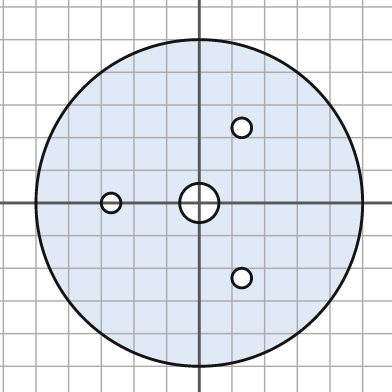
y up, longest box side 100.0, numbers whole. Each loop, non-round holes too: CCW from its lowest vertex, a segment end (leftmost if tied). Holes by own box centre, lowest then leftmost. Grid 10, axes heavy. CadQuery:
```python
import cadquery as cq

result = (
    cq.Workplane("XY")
    .moveTo(0.0, 0.0)
    .circle(50.0)
    .moveTo(13.0, -23.0)
    .circle(3.0)
    .moveTo(-27.0, 0.0)
    .circle(3.0)
    .moveTo(0.0, 0.0)
    .circle(6.0)
    .moveTo(13.0, 23.0)
    .circle(3.0)
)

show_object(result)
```